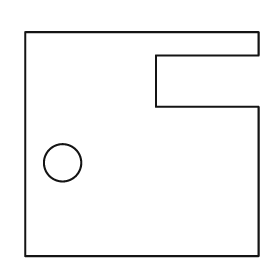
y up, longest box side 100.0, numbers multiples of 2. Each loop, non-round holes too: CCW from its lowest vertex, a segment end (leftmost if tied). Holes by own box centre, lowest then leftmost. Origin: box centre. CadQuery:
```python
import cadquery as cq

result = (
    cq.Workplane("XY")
    .moveTo(-50.0, -48.0)
    .lineTo(50.0, -48.0)
    .lineTo(50.0, 16.0)
    .lineTo(6.0, 16.0)
    .lineTo(6.0, 38.0)
    .lineTo(50.0, 38.0)
    .lineTo(50.0, 48.0)
    .lineTo(-50.0, 48.0)
    .close()
    .moveTo(-34.0, -8.0)
    .circle(8.0)
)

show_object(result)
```